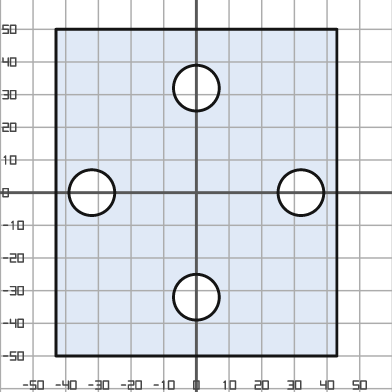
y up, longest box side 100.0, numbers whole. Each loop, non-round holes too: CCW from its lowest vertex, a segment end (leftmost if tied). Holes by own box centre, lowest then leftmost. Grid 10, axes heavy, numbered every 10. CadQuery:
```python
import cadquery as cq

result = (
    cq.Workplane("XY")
    .moveTo(-43.0, -50.0)
    .lineTo(43.0, -50.0)
    .lineTo(43.0, 50.0)
    .lineTo(-43.0, 50.0)
    .close()
    .moveTo(0.0, -32.0)
    .circle(7.0)
    .moveTo(-32.0, 0.0)
    .circle(7.0)
    .moveTo(32.0, 0.0)
    .circle(7.0)
    .moveTo(0.0, 32.0)
    .circle(7.0)
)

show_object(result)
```